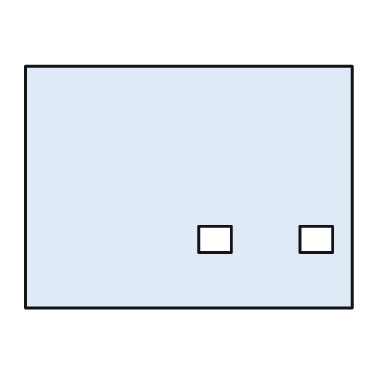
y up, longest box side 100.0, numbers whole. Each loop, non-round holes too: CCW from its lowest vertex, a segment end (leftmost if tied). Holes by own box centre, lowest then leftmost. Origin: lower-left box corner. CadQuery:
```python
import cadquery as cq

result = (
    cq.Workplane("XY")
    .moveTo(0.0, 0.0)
    .lineTo(100.0, 0.0)
    .lineTo(100.0, 74.0)
    .lineTo(0.0, 74.0)
    .close()
    .moveTo(53.0, 17.0)
    .lineTo(63.0, 17.0)
    .lineTo(63.0, 25.0)
    .lineTo(53.0, 25.0)
    .close()
    .moveTo(84.0, 17.0)
    .lineTo(94.0, 17.0)
    .lineTo(94.0, 25.0)
    .lineTo(84.0, 25.0)
    .close()
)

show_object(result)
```